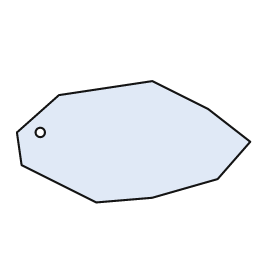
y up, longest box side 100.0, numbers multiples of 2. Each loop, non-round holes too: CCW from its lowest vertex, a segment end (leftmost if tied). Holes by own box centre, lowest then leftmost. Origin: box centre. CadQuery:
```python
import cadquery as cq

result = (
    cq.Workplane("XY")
    .moveTo(-16.0, -26.0)
    .lineTo(8.0, -24.0)
    .lineTo(36.0, -16.0)
    .lineTo(50.0, 0.0)
    .lineTo(32.0, 14.0)
    .lineTo(8.0, 26.0)
    .lineTo(-32.0, 20.0)
    .lineTo(-50.0, 4.0)
    .lineTo(-48.0, -10.0)
    .close()
    .moveTo(-40.0, 4.0)
    .circle(2.0)
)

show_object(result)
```